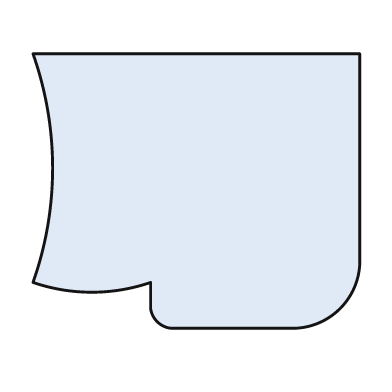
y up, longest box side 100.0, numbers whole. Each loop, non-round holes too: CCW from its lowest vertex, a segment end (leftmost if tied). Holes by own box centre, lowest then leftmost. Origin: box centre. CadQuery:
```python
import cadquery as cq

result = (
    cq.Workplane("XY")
    .moveTo(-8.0, -42.0)
    .lineTo(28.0, -42.0)
    .threePointArc((44.0, -36.0), (50.0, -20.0))
    .lineTo(50.0, 42.0)
    .lineTo(-50.0, 42.0)
    .threePointArc((-44.0, 7.0), (-50.0, -28.0))
    .threePointArc((-32.0, -31.0), (-14.0, -28.0))
    .lineTo(-14.0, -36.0)
    .threePointArc((-12.0, -40.0), (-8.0, -42.0))
    .close()
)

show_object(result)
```